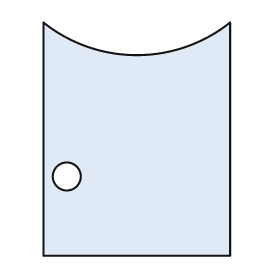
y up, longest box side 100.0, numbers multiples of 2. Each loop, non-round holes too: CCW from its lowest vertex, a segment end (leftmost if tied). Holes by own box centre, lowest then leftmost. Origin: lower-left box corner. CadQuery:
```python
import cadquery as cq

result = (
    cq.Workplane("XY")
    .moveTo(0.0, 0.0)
    .lineTo(80.0, 0.0)
    .lineTo(80.0, 100.0)
    .threePointArc((40.0, 86.0), (0.0, 100.0))
    .close()
    .moveTo(10.0, 34.0)
    .circle(6.0)
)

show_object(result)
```